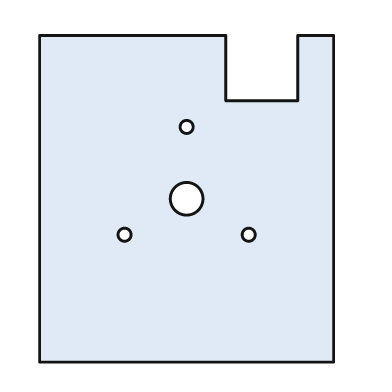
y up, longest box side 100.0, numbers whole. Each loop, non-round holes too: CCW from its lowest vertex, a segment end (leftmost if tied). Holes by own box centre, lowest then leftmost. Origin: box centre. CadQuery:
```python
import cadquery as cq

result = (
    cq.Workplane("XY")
    .moveTo(-45.0, -50.0)
    .lineTo(45.0, -50.0)
    .lineTo(45.0, 50.0)
    .lineTo(34.0, 50.0)
    .lineTo(34.0, 30.0)
    .lineTo(12.0, 30.0)
    .lineTo(12.0, 50.0)
    .lineTo(-45.0, 50.0)
    .close()
    .moveTo(-19.0, -11.0)
    .circle(2.0)
    .moveTo(19.0, -11.0)
    .circle(2.0)
    .moveTo(0.0, 0.0)
    .circle(5.0)
    .moveTo(0.0, 22.0)
    .circle(2.0)
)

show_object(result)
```